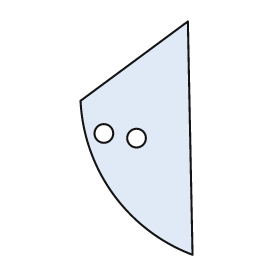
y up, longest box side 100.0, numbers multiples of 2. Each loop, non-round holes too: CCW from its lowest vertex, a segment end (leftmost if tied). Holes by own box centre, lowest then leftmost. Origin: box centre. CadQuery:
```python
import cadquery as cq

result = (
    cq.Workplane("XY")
    .moveTo(24.0, -50.0)
    .lineTo(22.0, 50.0)
    .lineTo(-24.0, 16.0)
    .threePointArc((-10.0, -24.0), (24.0, -50.0))
    .close()
    .moveTo(0.0, 0.0)
    .circle(4.0)
    .moveTo(-14.0, 2.0)
    .circle(4.0)
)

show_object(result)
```